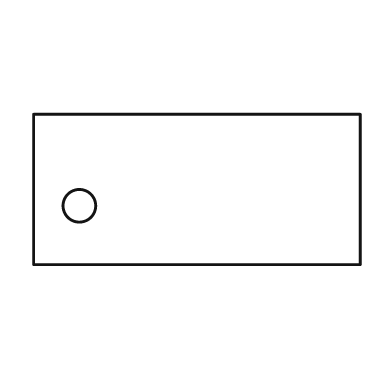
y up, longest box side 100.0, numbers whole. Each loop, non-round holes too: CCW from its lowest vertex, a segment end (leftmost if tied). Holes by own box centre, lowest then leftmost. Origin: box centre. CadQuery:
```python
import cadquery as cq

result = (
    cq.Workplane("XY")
    .moveTo(-50.0, -23.0)
    .lineTo(50.0, -23.0)
    .lineTo(50.0, 23.0)
    .lineTo(-50.0, 23.0)
    .close()
    .moveTo(-36.0, -5.0)
    .circle(5.0)
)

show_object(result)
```